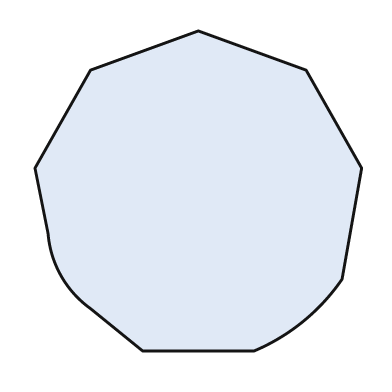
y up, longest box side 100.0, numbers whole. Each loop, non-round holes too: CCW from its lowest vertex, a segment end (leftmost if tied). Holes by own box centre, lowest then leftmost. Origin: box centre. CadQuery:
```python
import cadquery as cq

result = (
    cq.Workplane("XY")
    .moveTo(-17.0, -49.0)
    .lineTo(17.0, -49.0)
    .threePointArc((32.0, -40.0), (44.0, -27.0))
    .lineTo(50.0, 7.0)
    .lineTo(33.0, 37.0)
    .lineTo(0.0, 49.0)
    .lineTo(-33.0, 37.0)
    .lineTo(-50.0, 7.0)
    .lineTo(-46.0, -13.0)
    .threePointArc((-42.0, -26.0), (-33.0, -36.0))
    .close()
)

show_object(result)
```